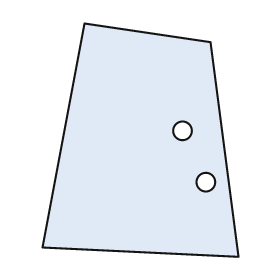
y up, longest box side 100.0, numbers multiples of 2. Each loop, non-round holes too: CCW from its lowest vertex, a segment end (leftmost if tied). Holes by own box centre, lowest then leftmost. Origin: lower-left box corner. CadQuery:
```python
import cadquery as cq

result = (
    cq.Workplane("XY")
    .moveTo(84.0, 0.0)
    .lineTo(72.0, 92.0)
    .lineTo(18.0, 100.0)
    .lineTo(0.0, 4.0)
    .close()
    .moveTo(70.0, 32.0)
    .circle(4.0)
    .moveTo(60.0, 54.0)
    .circle(4.0)
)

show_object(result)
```